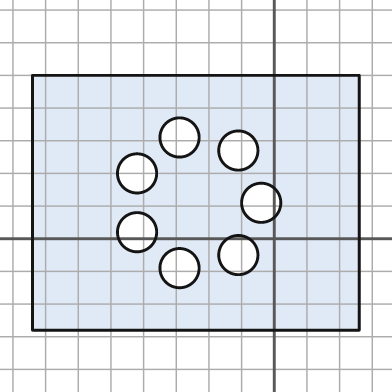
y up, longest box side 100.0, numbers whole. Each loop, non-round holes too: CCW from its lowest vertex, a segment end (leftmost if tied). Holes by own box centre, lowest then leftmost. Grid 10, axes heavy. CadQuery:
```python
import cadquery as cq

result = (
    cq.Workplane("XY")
    .moveTo(-74.0, -28.0)
    .lineTo(26.0, -28.0)
    .lineTo(26.0, 50.0)
    .lineTo(-74.0, 50.0)
    .close()
    .moveTo(-29.0, -9.0)
    .circle(6.0)
    .moveTo(-11.0, -5.0)
    .circle(6.0)
    .moveTo(-42.0, 2.0)
    .circle(6.0)
    .moveTo(-4.0, 11.0)
    .circle(6.0)
    .moveTo(-42.0, 20.0)
    .circle(6.0)
    .moveTo(-11.0, 27.0)
    .circle(6.0)
    .moveTo(-29.0, 31.0)
    .circle(6.0)
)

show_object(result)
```